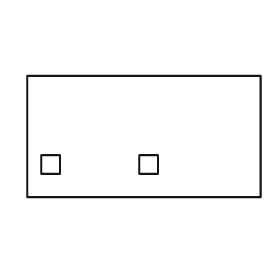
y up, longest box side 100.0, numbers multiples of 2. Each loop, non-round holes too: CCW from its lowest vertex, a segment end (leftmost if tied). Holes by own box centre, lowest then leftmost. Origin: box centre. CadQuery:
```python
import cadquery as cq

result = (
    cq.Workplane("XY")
    .moveTo(-50.0, -26.0)
    .lineTo(50.0, -26.0)
    .lineTo(50.0, 26.0)
    .lineTo(-50.0, 26.0)
    .close()
    .moveTo(-44.0, -16.0)
    .lineTo(-36.0, -16.0)
    .lineTo(-36.0, -8.0)
    .lineTo(-44.0, -8.0)
    .close()
    .moveTo(-2.0, -16.0)
    .lineTo(6.0, -16.0)
    .lineTo(6.0, -8.0)
    .lineTo(-2.0, -8.0)
    .close()
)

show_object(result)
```